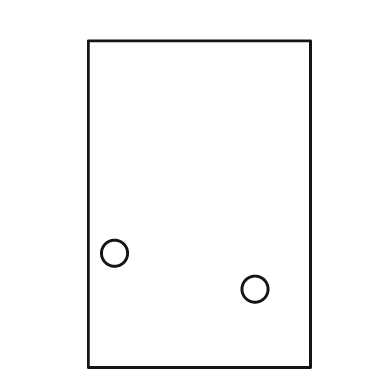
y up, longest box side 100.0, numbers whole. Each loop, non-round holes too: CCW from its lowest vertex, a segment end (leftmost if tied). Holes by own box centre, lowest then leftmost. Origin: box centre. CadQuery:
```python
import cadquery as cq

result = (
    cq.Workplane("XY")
    .moveTo(-34.0, -50.0)
    .lineTo(34.0, -50.0)
    .lineTo(34.0, 50.0)
    .lineTo(-34.0, 50.0)
    .close()
    .moveTo(17.0, -26.0)
    .circle(4.0)
    .moveTo(-26.0, -15.0)
    .circle(4.0)
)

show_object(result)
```